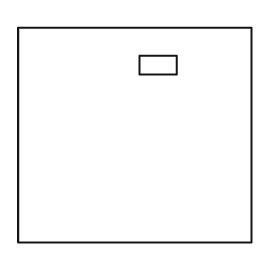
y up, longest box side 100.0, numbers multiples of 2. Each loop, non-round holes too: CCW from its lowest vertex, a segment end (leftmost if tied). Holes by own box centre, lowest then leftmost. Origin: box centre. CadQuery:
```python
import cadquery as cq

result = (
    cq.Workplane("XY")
    .moveTo(-50.0, -46.0)
    .lineTo(50.0, -46.0)
    .lineTo(50.0, 46.0)
    .lineTo(-50.0, 46.0)
    .close()
    .moveTo(2.0, 26.0)
    .lineTo(18.0, 26.0)
    .lineTo(18.0, 34.0)
    .lineTo(2.0, 34.0)
    .close()
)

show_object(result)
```